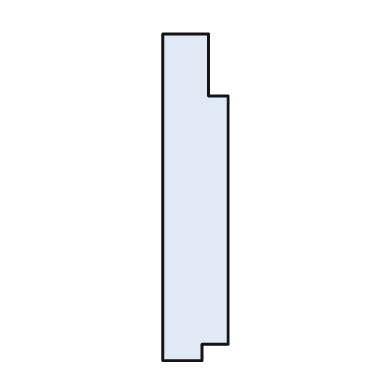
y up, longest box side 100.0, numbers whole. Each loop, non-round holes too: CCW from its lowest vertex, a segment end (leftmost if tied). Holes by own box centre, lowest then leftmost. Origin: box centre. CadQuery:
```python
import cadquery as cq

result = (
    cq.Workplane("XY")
    .moveTo(-10.0, -50.0)
    .lineTo(2.0, -50.0)
    .lineTo(2.0, -45.0)
    .lineTo(10.0, -45.0)
    .lineTo(10.0, 31.0)
    .lineTo(4.0, 31.0)
    .lineTo(4.0, 50.0)
    .lineTo(-10.0, 50.0)
    .close()
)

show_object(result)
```